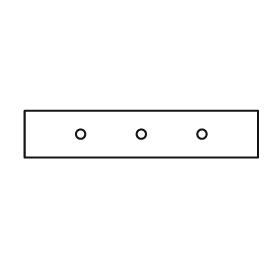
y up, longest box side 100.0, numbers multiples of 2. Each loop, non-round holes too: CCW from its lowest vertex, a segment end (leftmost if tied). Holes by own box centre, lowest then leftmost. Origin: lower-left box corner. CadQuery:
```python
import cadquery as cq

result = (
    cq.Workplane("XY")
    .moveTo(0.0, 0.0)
    .lineTo(100.0, 0.0)
    .lineTo(100.0, 20.0)
    .lineTo(0.0, 20.0)
    .close()
    .moveTo(24.0, 10.0)
    .circle(2.0)
    .moveTo(50.0, 10.0)
    .circle(2.0)
    .moveTo(76.0, 10.0)
    .circle(2.0)
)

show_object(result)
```